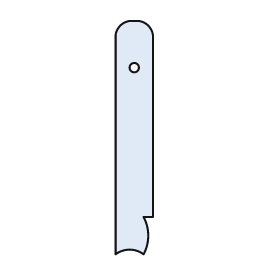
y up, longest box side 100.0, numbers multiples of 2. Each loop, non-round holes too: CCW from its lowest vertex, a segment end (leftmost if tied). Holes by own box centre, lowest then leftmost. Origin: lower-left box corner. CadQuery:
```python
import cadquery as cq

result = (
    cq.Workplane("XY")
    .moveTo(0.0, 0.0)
    .threePointArc((6.0, 2.0), (12.0, 0.0))
    .threePointArc((14.0, 8.0), (12.0, 16.0))
    .lineTo(16.0, 16.0)
    .lineTo(16.0, 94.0)
    .threePointArc((14.0, 98.0), (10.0, 100.0))
    .lineTo(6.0, 100.0)
    .threePointArc((2.0, 98.0), (0.0, 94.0))
    .close()
    .moveTo(8.0, 80.0)
    .circle(2.0)
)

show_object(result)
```